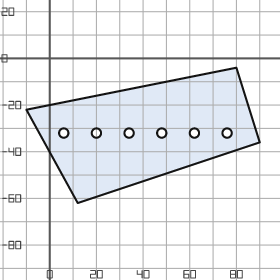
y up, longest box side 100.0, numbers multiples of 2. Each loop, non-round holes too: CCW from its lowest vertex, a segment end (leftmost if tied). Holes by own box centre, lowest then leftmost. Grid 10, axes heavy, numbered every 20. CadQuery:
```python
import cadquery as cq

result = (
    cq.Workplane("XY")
    .moveTo(12.0, -62.0)
    .lineTo(90.0, -36.0)
    .lineTo(80.0, -4.0)
    .lineTo(-10.0, -22.0)
    .close()
    .moveTo(6.0, -32.0)
    .circle(2.0)
    .moveTo(20.0, -32.0)
    .circle(2.0)
    .moveTo(34.0, -32.0)
    .circle(2.0)
    .moveTo(48.0, -32.0)
    .circle(2.0)
    .moveTo(62.0, -32.0)
    .circle(2.0)
    .moveTo(76.0, -32.0)
    .circle(2.0)
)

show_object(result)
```